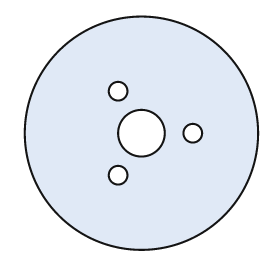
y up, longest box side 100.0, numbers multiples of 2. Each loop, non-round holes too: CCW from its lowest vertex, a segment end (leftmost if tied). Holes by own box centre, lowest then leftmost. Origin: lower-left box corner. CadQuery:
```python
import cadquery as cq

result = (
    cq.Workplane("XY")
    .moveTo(50.0, 50.0)
    .circle(50.0)
    .moveTo(40.0, 32.0)
    .circle(4.0)
    .moveTo(50.0, 50.0)
    .circle(10.0)
    .moveTo(72.0, 50.0)
    .circle(4.0)
    .moveTo(40.0, 68.0)
    .circle(4.0)
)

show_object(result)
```